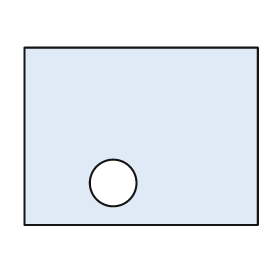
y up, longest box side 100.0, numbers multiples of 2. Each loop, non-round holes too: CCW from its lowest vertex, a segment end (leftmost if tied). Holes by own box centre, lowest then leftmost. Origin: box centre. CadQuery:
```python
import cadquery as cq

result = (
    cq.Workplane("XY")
    .moveTo(-50.0, -38.0)
    .lineTo(50.0, -38.0)
    .lineTo(50.0, 38.0)
    .lineTo(-50.0, 38.0)
    .close()
    .moveTo(-12.0, -20.0)
    .circle(10.0)
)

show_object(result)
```